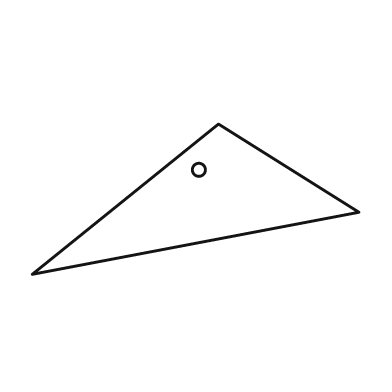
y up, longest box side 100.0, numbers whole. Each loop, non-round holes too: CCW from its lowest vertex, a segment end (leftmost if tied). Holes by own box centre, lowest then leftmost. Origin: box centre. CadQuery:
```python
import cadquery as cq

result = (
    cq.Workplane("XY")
    .moveTo(-50.0, -23.0)
    .lineTo(50.0, -4.0)
    .lineTo(7.0, 23.0)
    .close()
    .moveTo(1.0, 9.0)
    .circle(2.0)
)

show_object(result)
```